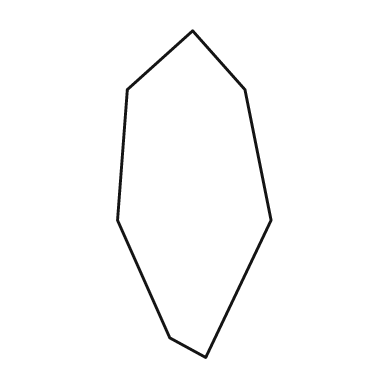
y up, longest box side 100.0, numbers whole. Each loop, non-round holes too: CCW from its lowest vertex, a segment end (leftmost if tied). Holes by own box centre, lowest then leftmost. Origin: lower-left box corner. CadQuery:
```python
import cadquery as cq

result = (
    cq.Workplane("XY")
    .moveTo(27.0, 0.0)
    .lineTo(47.0, 42.0)
    .lineTo(39.0, 82.0)
    .lineTo(23.0, 100.0)
    .lineTo(3.0, 82.0)
    .lineTo(0.0, 42.0)
    .lineTo(16.0, 6.0)
    .close()
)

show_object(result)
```